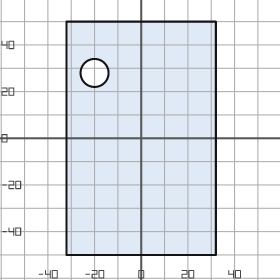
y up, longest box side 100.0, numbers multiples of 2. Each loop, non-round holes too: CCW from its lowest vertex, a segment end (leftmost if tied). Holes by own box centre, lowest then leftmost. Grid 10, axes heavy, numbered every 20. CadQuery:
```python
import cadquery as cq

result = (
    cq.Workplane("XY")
    .moveTo(-32.0, -50.0)
    .lineTo(32.0, -50.0)
    .lineTo(32.0, 50.0)
    .lineTo(-32.0, 50.0)
    .close()
    .moveTo(-20.0, 28.0)
    .circle(6.0)
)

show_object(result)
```